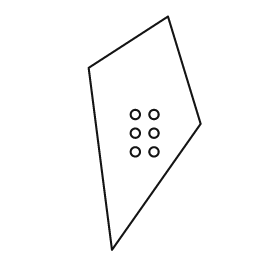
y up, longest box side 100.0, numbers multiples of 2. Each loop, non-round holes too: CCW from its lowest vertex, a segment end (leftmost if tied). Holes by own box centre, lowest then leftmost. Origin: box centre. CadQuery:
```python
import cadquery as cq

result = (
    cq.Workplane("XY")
    .moveTo(-14.0, -50.0)
    .lineTo(24.0, 4.0)
    .lineTo(10.0, 50.0)
    .lineTo(-24.0, 28.0)
    .close()
    .moveTo(-4.0, -8.0)
    .circle(2.0)
    .moveTo(4.0, -8.0)
    .circle(2.0)
    .moveTo(-4.0, 0.0)
    .circle(2.0)
    .moveTo(4.0, 0.0)
    .circle(2.0)
    .moveTo(-4.0, 8.0)
    .circle(2.0)
    .moveTo(4.0, 8.0)
    .circle(2.0)
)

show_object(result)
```